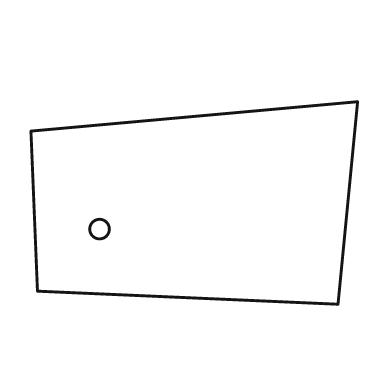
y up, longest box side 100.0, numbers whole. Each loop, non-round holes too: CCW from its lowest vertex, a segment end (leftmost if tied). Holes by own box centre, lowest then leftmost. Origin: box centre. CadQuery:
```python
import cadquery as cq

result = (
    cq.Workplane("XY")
    .moveTo(44.0, -31.0)
    .lineTo(50.0, 31.0)
    .lineTo(-50.0, 22.0)
    .lineTo(-48.0, -27.0)
    .close()
    .moveTo(-29.0, -8.0)
    .circle(3.0)
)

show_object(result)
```